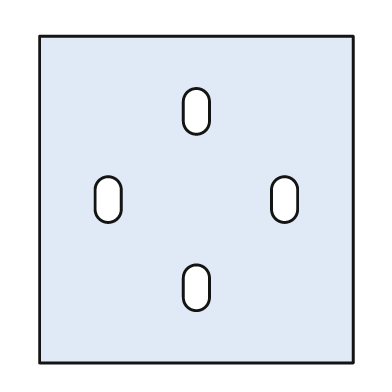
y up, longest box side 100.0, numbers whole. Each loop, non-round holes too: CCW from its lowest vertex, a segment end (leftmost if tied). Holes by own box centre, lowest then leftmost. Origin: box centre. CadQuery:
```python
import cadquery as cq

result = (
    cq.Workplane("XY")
    .moveTo(-48.0, -50.0)
    .lineTo(48.0, -50.0)
    .lineTo(48.0, 50.0)
    .lineTo(-48.0, 50.0)
    .close()
    .moveTo(-4.0, -30.0)
    .threePointArc((0.0, -34.0), (4.0, -30.0))
    .lineTo(4.0, -24.0)
    .threePointArc((0.0, -20.0), (-4.0, -24.0))
    .close()
    .moveTo(-31.0, -3.0)
    .threePointArc((-27.0, -7.0), (-23.0, -3.0))
    .lineTo(-23.0, 3.0)
    .threePointArc((-27.0, 7.0), (-31.0, 3.0))
    .close()
    .moveTo(23.0, -3.0)
    .threePointArc((27.0, -7.0), (31.0, -3.0))
    .lineTo(31.0, 3.0)
    .threePointArc((27.0, 7.0), (23.0, 3.0))
    .close()
    .moveTo(-4.0, 24.0)
    .threePointArc((0.0, 20.0), (4.0, 24.0))
    .lineTo(4.0, 30.0)
    .threePointArc((0.0, 34.0), (-4.0, 30.0))
    .close()
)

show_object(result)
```